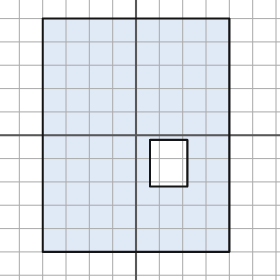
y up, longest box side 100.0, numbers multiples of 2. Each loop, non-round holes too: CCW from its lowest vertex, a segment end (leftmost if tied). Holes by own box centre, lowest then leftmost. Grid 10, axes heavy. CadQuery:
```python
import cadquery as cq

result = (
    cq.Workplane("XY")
    .moveTo(-40.0, -50.0)
    .lineTo(40.0, -50.0)
    .lineTo(40.0, 50.0)
    .lineTo(-40.0, 50.0)
    .close()
    .moveTo(6.0, -22.0)
    .lineTo(22.0, -22.0)
    .lineTo(22.0, -2.0)
    .lineTo(6.0, -2.0)
    .close()
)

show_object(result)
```